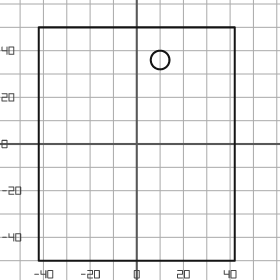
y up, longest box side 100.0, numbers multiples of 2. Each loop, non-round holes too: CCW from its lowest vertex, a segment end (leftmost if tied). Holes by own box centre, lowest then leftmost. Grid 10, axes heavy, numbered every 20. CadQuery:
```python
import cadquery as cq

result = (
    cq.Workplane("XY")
    .moveTo(-42.0, -50.0)
    .lineTo(42.0, -50.0)
    .lineTo(42.0, 50.0)
    .lineTo(-42.0, 50.0)
    .close()
    .moveTo(10.0, 36.0)
    .circle(4.0)
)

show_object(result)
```